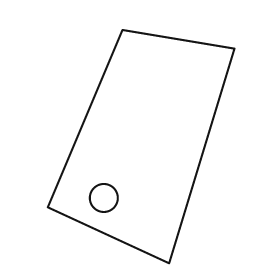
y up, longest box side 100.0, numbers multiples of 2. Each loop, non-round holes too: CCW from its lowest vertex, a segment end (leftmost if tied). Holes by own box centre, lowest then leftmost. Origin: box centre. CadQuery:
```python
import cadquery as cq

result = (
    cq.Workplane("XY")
    .moveTo(12.0, -50.0)
    .lineTo(40.0, 42.0)
    .lineTo(-8.0, 50.0)
    .lineTo(-40.0, -26.0)
    .close()
    .moveTo(-16.0, -22.0)
    .circle(6.0)
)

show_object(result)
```